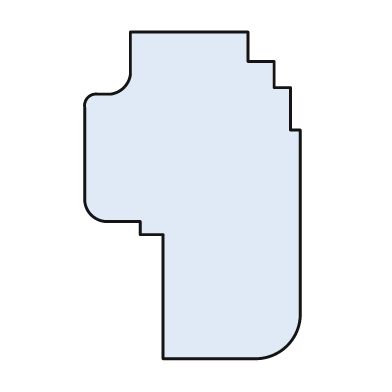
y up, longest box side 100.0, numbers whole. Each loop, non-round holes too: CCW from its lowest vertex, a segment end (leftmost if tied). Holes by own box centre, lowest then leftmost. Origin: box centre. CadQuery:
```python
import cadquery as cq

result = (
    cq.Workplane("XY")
    .moveTo(-9.0, -50.0)
    .lineTo(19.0, -50.0)
    .threePointArc((29.0, -46.0), (33.0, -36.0))
    .lineTo(33.0, 20.0)
    .lineTo(30.0, 20.0)
    .lineTo(30.0, 33.0)
    .lineTo(25.0, 33.0)
    .lineTo(25.0, 41.0)
    .lineTo(17.0, 41.0)
    .lineTo(17.0, 50.0)
    .lineTo(-19.0, 50.0)
    .lineTo(-19.0, 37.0)
    .threePointArc((-21.0, 33.0), (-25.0, 31.0))
    .lineTo(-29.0, 31.0)
    .threePointArc((-32.0, 30.0), (-33.0, 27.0))
    .lineTo(-33.0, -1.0)
    .threePointArc((-31.0, -6.0), (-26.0, -8.0))
    .lineTo(-16.0, -8.0)
    .lineTo(-16.0, -12.0)
    .lineTo(-9.0, -12.0)
    .close()
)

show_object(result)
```